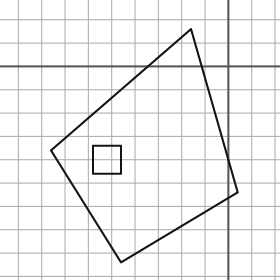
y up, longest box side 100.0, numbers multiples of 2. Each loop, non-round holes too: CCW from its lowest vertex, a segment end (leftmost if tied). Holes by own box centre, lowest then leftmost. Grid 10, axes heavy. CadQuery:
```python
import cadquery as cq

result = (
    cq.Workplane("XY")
    .moveTo(-46.0, -84.0)
    .lineTo(4.0, -54.0)
    .lineTo(-16.0, 16.0)
    .lineTo(-76.0, -36.0)
    .close()
    .moveTo(-58.0, -46.0)
    .lineTo(-46.0, -46.0)
    .lineTo(-46.0, -34.0)
    .lineTo(-58.0, -34.0)
    .close()
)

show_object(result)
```